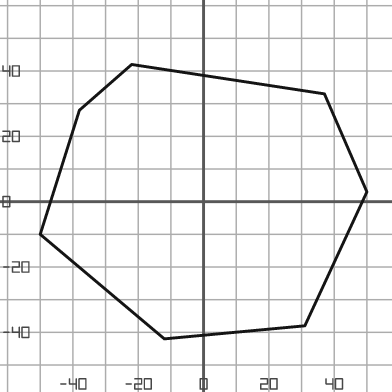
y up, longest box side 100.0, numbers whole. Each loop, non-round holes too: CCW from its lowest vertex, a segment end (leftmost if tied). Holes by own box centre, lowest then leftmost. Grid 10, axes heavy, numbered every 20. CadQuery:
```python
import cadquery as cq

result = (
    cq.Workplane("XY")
    .moveTo(-12.0, -42.0)
    .lineTo(31.0, -38.0)
    .lineTo(50.0, 3.0)
    .lineTo(37.0, 33.0)
    .lineTo(-22.0, 42.0)
    .lineTo(-38.0, 28.0)
    .lineTo(-50.0, -10.0)
    .close()
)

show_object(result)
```